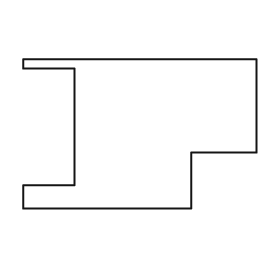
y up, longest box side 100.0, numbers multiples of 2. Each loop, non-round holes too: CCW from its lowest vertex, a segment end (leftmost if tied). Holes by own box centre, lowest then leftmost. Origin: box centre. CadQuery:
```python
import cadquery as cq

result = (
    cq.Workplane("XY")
    .moveTo(-50.0, -32.0)
    .lineTo(22.0, -32.0)
    .lineTo(22.0, -8.0)
    .lineTo(50.0, -8.0)
    .lineTo(50.0, 32.0)
    .lineTo(-50.0, 32.0)
    .lineTo(-50.0, 28.0)
    .lineTo(-28.0, 28.0)
    .lineTo(-28.0, -22.0)
    .lineTo(-50.0, -22.0)
    .close()
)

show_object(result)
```